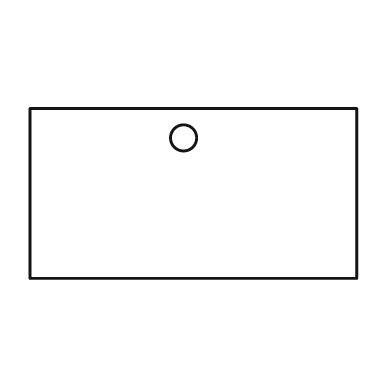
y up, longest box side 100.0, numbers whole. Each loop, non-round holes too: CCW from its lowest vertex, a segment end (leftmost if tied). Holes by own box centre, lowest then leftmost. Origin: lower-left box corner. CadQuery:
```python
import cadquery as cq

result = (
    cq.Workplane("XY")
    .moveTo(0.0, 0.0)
    .lineTo(100.0, 0.0)
    .lineTo(100.0, 52.0)
    .lineTo(0.0, 52.0)
    .close()
    .moveTo(47.0, 43.0)
    .circle(4.0)
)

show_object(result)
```